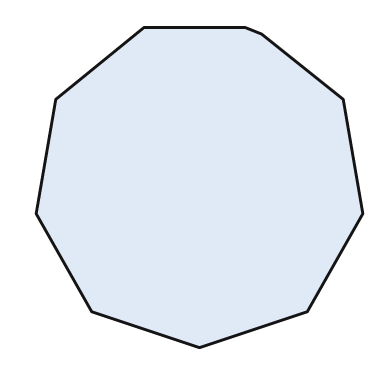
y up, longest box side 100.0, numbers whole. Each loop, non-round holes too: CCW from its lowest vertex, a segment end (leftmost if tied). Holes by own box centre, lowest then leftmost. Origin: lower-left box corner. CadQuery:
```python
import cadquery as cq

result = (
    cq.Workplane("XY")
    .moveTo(50.0, 0.0)
    .lineTo(83.0, 11.0)
    .lineTo(100.0, 41.0)
    .lineTo(94.0, 76.0)
    .lineTo(69.0, 96.0)
    .lineTo(64.0, 98.0)
    .lineTo(33.0, 98.0)
    .lineTo(6.0, 76.0)
    .lineTo(0.0, 41.0)
    .lineTo(17.0, 11.0)
    .close()
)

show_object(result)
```